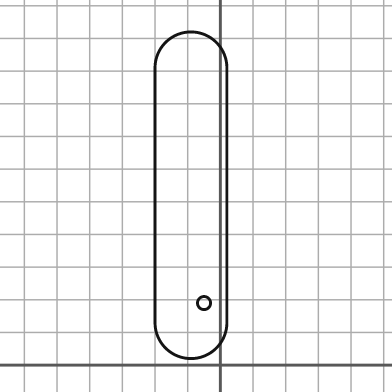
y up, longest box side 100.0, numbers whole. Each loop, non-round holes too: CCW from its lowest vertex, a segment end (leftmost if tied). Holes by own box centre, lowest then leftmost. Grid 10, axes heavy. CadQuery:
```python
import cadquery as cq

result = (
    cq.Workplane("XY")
    .moveTo(-20.0, 13.0)
    .threePointArc((-9.0, 2.0), (2.0, 13.0))
    .lineTo(2.0, 91.0)
    .threePointArc((-9.0, 102.0), (-20.0, 91.0))
    .close()
    .moveTo(-5.0, 19.0)
    .circle(2.0)
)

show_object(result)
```